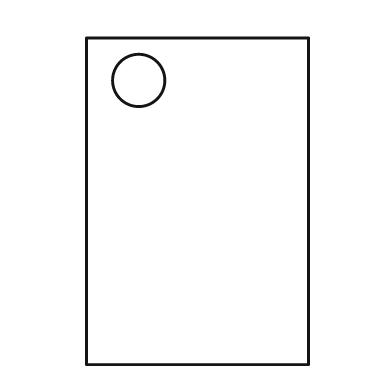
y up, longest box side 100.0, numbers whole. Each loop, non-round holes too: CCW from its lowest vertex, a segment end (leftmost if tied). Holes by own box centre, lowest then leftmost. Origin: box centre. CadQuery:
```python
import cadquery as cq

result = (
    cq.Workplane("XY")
    .moveTo(-34.0, -50.0)
    .lineTo(34.0, -50.0)
    .lineTo(34.0, 50.0)
    .lineTo(-34.0, 50.0)
    .close()
    .moveTo(-18.0, 37.0)
    .circle(8.0)
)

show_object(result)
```